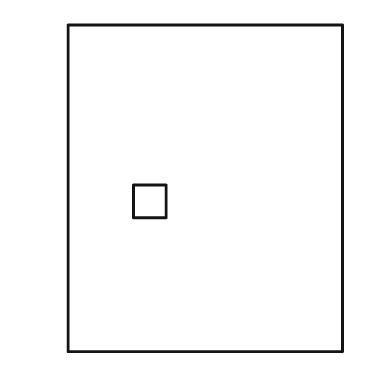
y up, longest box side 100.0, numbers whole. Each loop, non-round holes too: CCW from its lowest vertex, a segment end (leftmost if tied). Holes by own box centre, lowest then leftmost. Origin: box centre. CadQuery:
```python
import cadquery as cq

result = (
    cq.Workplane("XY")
    .moveTo(-42.0, -50.0)
    .lineTo(42.0, -50.0)
    .lineTo(42.0, 50.0)
    .lineTo(-42.0, 50.0)
    .close()
    .moveTo(-22.0, -9.0)
    .lineTo(-12.0, -9.0)
    .lineTo(-12.0, 1.0)
    .lineTo(-22.0, 1.0)
    .close()
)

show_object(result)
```